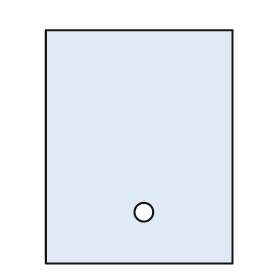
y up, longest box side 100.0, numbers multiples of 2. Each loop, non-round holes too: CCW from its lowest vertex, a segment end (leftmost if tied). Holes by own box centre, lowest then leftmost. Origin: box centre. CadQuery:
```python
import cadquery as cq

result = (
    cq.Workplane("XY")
    .moveTo(-40.0, -50.0)
    .lineTo(40.0, -50.0)
    .lineTo(40.0, 50.0)
    .lineTo(-40.0, 50.0)
    .close()
    .moveTo(2.0, -28.0)
    .circle(4.0)
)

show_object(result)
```